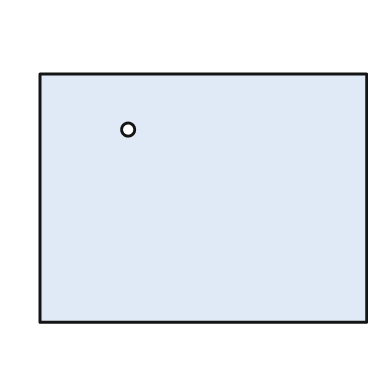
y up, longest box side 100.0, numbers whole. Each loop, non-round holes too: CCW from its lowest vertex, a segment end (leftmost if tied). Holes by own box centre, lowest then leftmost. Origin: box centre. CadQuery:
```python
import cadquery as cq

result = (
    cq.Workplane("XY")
    .moveTo(-50.0, -38.0)
    .lineTo(50.0, -38.0)
    .lineTo(50.0, 38.0)
    .lineTo(-50.0, 38.0)
    .close()
    .moveTo(-23.0, 21.0)
    .circle(2.0)
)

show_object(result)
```